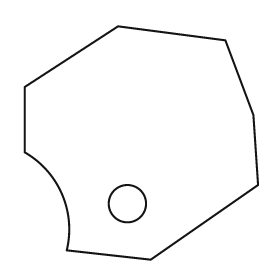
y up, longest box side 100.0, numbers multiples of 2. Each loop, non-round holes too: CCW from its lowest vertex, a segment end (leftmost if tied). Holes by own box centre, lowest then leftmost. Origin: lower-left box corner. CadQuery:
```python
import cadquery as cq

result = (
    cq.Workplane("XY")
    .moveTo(54.0, 0.0)
    .lineTo(100.0, 32.0)
    .lineTo(98.0, 62.0)
    .lineTo(86.0, 94.0)
    .lineTo(40.0, 100.0)
    .lineTo(0.0, 74.0)
    .lineTo(0.0, 46.0)
    .threePointArc((16.0, 28.0), (18.0, 4.0))
    .close()
    .moveTo(44.0, 24.0)
    .circle(8.0)
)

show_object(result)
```